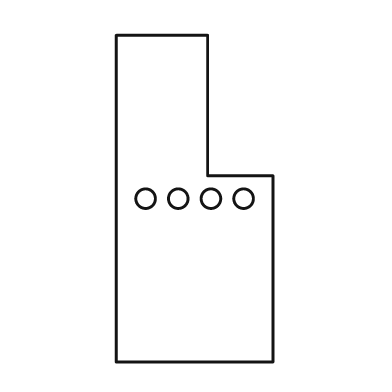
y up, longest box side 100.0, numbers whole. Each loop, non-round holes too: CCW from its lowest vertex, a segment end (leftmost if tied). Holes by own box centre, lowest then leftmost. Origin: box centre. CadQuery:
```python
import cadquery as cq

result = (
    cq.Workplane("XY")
    .moveTo(-24.0, -50.0)
    .lineTo(24.0, -50.0)
    .lineTo(24.0, 7.0)
    .lineTo(4.0, 7.0)
    .lineTo(4.0, 50.0)
    .lineTo(-24.0, 50.0)
    .close()
    .moveTo(-15.0, 0.0)
    .circle(3.0)
    .moveTo(-5.0, 0.0)
    .circle(3.0)
    .moveTo(5.0, 0.0)
    .circle(3.0)
    .moveTo(15.0, 0.0)
    .circle(3.0)
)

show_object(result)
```